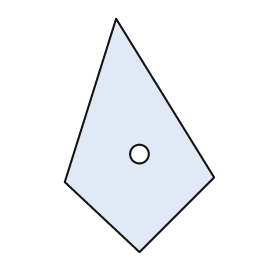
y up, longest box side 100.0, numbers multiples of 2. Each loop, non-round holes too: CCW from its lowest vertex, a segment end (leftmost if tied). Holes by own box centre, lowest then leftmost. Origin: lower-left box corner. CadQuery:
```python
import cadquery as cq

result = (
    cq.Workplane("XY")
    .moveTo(32.0, 0.0)
    .lineTo(64.0, 32.0)
    .lineTo(22.0, 100.0)
    .lineTo(0.0, 30.0)
    .close()
    .moveTo(32.0, 42.0)
    .circle(4.0)
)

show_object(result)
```